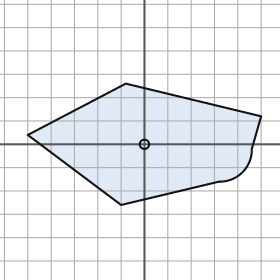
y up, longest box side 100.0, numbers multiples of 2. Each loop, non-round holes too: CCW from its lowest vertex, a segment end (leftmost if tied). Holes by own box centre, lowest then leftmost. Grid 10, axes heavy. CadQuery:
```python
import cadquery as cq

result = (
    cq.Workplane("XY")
    .moveTo(-10.0, -26.0)
    .lineTo(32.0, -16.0)
    .threePointArc((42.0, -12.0), (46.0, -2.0))
    .lineTo(50.0, 12.0)
    .lineTo(-8.0, 26.0)
    .lineTo(-50.0, 4.0)
    .close()
    .moveTo(0.0, 0.0)
    .circle(2.0)
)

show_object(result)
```